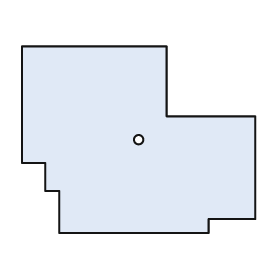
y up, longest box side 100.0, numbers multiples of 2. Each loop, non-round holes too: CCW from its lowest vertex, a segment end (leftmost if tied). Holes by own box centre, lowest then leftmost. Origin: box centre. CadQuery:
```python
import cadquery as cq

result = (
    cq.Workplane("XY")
    .moveTo(-34.0, -40.0)
    .lineTo(30.0, -40.0)
    .lineTo(30.0, -34.0)
    .lineTo(50.0, -34.0)
    .lineTo(50.0, 10.0)
    .lineTo(12.0, 10.0)
    .lineTo(12.0, 40.0)
    .lineTo(-50.0, 40.0)
    .lineTo(-50.0, -10.0)
    .lineTo(-40.0, -10.0)
    .lineTo(-40.0, -22.0)
    .lineTo(-34.0, -22.0)
    .close()
    .moveTo(0.0, 0.0)
    .circle(2.0)
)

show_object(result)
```